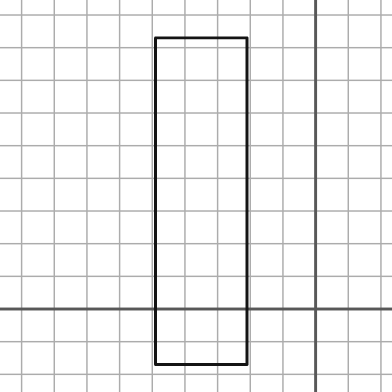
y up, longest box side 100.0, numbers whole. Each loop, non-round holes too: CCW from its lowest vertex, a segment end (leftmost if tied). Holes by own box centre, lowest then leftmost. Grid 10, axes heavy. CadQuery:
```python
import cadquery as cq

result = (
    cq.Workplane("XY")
    .moveTo(-49.0, -17.0)
    .lineTo(-21.0, -17.0)
    .lineTo(-21.0, 83.0)
    .lineTo(-49.0, 83.0)
    .close()
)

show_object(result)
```